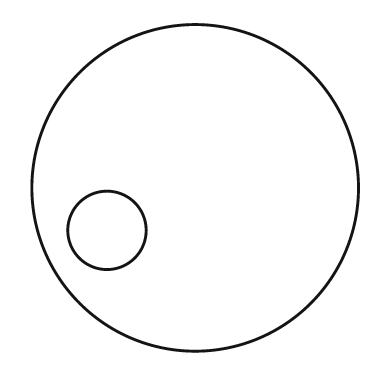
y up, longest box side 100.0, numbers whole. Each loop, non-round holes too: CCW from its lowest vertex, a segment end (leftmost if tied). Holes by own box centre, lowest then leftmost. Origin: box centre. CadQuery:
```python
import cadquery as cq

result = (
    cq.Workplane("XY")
    .moveTo(0.0, 0.0)
    .circle(50.0)
    .moveTo(-27.0, -13.0)
    .circle(12.0)
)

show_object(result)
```